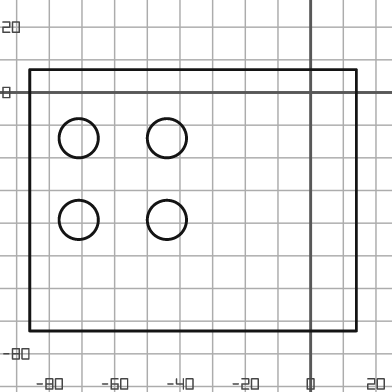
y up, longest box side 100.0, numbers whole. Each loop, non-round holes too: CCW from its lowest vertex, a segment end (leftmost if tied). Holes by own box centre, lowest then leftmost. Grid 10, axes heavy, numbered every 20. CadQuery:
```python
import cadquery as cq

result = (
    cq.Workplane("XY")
    .moveTo(-86.0, -73.0)
    .lineTo(14.0, -73.0)
    .lineTo(14.0, 7.0)
    .lineTo(-86.0, 7.0)
    .close()
    .moveTo(-71.0, -39.0)
    .circle(6.0)
    .moveTo(-44.0, -39.0)
    .circle(6.0)
    .moveTo(-71.0, -14.0)
    .circle(6.0)
    .moveTo(-44.0, -14.0)
    .circle(6.0)
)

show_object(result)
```